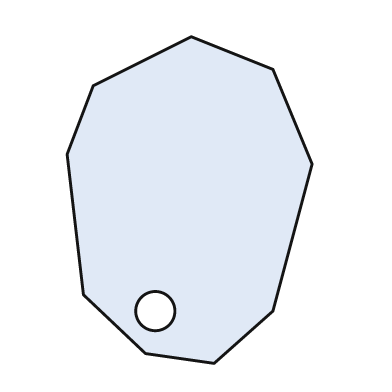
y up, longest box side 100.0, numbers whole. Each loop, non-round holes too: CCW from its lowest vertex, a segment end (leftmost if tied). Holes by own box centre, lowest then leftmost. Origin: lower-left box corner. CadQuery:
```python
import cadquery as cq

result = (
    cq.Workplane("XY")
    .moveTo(45.0, 0.0)
    .lineTo(63.0, 16.0)
    .lineTo(75.0, 61.0)
    .lineTo(63.0, 90.0)
    .lineTo(38.0, 100.0)
    .lineTo(8.0, 85.0)
    .lineTo(0.0, 64.0)
    .lineTo(5.0, 21.0)
    .lineTo(24.0, 3.0)
    .close()
    .moveTo(27.0, 16.0)
    .circle(6.0)
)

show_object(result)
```